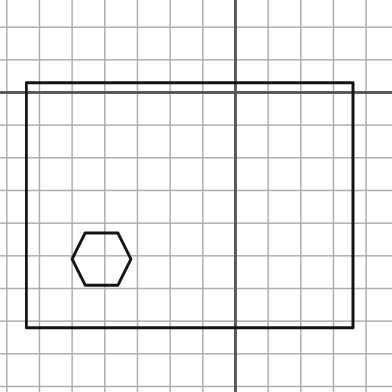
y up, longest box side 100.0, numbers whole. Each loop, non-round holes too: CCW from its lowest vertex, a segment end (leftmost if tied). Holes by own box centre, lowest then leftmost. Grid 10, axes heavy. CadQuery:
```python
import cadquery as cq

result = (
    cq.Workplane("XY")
    .moveTo(-64.0, -72.0)
    .lineTo(36.0, -72.0)
    .lineTo(36.0, 3.0)
    .lineTo(-64.0, 3.0)
    .close()
    .moveTo(-46.0, -59.0)
    .lineTo(-36.0, -59.0)
    .lineTo(-32.0, -51.0)
    .lineTo(-36.0, -43.0)
    .lineTo(-46.0, -43.0)
    .lineTo(-50.0, -51.0)
    .close()
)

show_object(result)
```